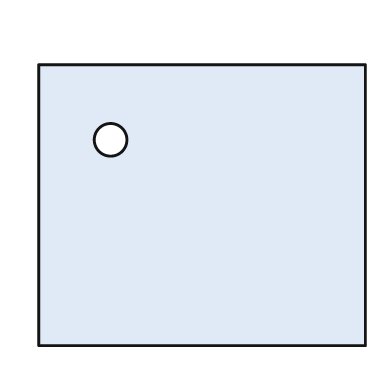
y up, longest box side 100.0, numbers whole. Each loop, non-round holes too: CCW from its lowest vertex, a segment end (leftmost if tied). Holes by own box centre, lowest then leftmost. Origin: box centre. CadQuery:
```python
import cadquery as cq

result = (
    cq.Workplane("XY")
    .moveTo(-50.0, -43.0)
    .lineTo(50.0, -43.0)
    .lineTo(50.0, 43.0)
    .lineTo(-50.0, 43.0)
    .close()
    .moveTo(-28.0, 20.0)
    .circle(5.0)
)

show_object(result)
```